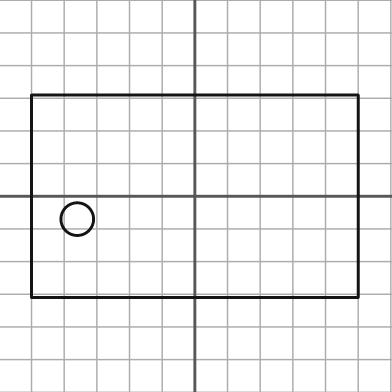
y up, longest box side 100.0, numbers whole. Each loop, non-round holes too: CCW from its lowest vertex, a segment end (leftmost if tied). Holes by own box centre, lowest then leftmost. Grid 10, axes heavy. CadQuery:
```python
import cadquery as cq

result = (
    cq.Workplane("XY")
    .moveTo(-50.0, -31.0)
    .lineTo(50.0, -31.0)
    .lineTo(50.0, 31.0)
    .lineTo(-50.0, 31.0)
    .close()
    .moveTo(-36.0, -7.0)
    .circle(5.0)
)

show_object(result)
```